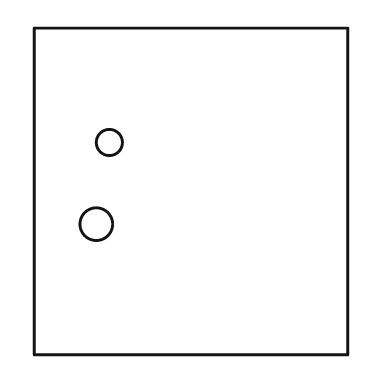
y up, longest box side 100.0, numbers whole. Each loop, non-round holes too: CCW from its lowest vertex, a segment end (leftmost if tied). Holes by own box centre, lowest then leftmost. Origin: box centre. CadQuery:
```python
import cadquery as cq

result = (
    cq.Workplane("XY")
    .moveTo(-48.0, -50.0)
    .lineTo(48.0, -50.0)
    .lineTo(48.0, 50.0)
    .lineTo(-48.0, 50.0)
    .close()
    .moveTo(-29.0, -10.0)
    .circle(5.0)
    .moveTo(-25.0, 15.0)
    .circle(4.0)
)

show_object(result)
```